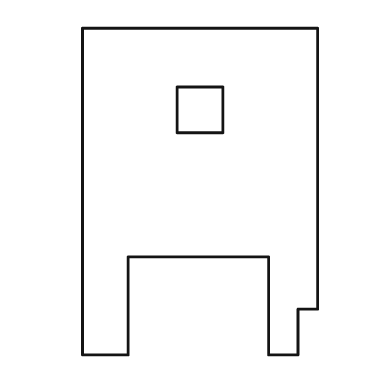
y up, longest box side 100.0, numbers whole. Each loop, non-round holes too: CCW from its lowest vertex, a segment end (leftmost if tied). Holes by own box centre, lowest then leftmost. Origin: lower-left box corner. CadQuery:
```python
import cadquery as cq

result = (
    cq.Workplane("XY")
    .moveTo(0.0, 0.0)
    .lineTo(14.0, 0.0)
    .lineTo(14.0, 30.0)
    .lineTo(57.0, 30.0)
    .lineTo(57.0, 0.0)
    .lineTo(66.0, 0.0)
    .lineTo(66.0, 14.0)
    .lineTo(72.0, 14.0)
    .lineTo(72.0, 100.0)
    .lineTo(0.0, 100.0)
    .close()
    .moveTo(29.0, 68.0)
    .lineTo(43.0, 68.0)
    .lineTo(43.0, 82.0)
    .lineTo(29.0, 82.0)
    .close()
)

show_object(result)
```